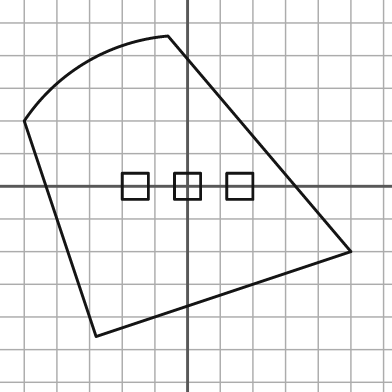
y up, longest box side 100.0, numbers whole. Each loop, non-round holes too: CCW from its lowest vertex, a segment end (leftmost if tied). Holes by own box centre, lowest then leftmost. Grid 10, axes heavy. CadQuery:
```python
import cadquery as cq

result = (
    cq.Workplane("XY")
    .moveTo(-28.0, -46.0)
    .lineTo(50.0, -20.0)
    .lineTo(-6.0, 46.0)
    .threePointArc((-31.0, 38.0), (-50.0, 20.0))
    .close()
    .moveTo(-20.0, -4.0)
    .lineTo(-12.0, -4.0)
    .lineTo(-12.0, 4.0)
    .lineTo(-20.0, 4.0)
    .close()
    .moveTo(-4.0, -4.0)
    .lineTo(4.0, -4.0)
    .lineTo(4.0, 4.0)
    .lineTo(-4.0, 4.0)
    .close()
    .moveTo(12.0, -4.0)
    .lineTo(20.0, -4.0)
    .lineTo(20.0, 4.0)
    .lineTo(12.0, 4.0)
    .close()
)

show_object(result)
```